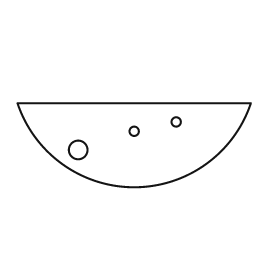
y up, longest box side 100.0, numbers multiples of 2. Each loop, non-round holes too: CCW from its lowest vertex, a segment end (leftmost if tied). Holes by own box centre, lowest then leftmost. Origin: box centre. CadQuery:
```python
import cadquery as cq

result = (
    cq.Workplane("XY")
    .moveTo(-50.0, 18.0)
    .threePointArc((0.0, -18.0), (50.0, 18.0))
    .close()
    .moveTo(-24.0, -2.0)
    .circle(4.0)
    .moveTo(0.0, 6.0)
    .circle(2.0)
    .moveTo(18.0, 10.0)
    .circle(2.0)
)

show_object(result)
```